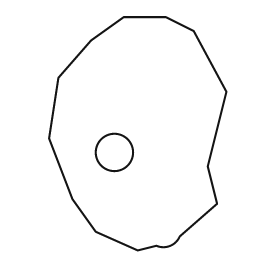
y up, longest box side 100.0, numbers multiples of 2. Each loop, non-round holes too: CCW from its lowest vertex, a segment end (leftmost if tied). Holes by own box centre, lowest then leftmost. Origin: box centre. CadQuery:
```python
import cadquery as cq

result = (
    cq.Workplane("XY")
    .moveTo(0.0, -50.0)
    .lineTo(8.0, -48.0)
    .threePointArc((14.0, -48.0), (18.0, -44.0))
    .lineTo(34.0, -30.0)
    .lineTo(30.0, -14.0)
    .lineTo(38.0, 18.0)
    .lineTo(24.0, 44.0)
    .lineTo(12.0, 50.0)
    .lineTo(-6.0, 50.0)
    .lineTo(-20.0, 40.0)
    .lineTo(-34.0, 24.0)
    .lineTo(-38.0, -2.0)
    .lineTo(-28.0, -28.0)
    .lineTo(-18.0, -42.0)
    .close()
    .moveTo(-10.0, -8.0)
    .circle(8.0)
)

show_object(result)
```